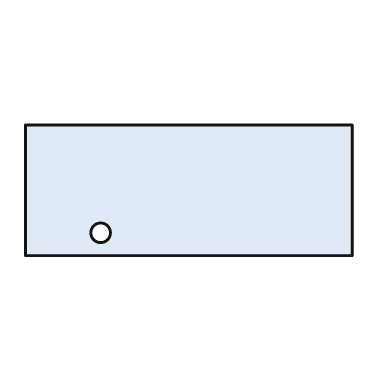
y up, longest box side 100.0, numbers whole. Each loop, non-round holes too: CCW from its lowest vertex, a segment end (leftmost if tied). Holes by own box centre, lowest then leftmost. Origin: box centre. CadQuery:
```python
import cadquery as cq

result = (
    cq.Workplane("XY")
    .moveTo(-50.0, -20.0)
    .lineTo(50.0, -20.0)
    .lineTo(50.0, 20.0)
    .lineTo(-50.0, 20.0)
    .close()
    .moveTo(-27.0, -13.0)
    .circle(3.0)
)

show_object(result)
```